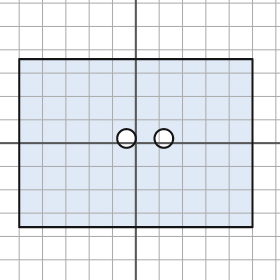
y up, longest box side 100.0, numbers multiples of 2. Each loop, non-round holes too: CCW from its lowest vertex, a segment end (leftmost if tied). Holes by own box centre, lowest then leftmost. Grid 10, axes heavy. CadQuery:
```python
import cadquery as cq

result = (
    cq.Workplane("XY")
    .moveTo(-50.0, -36.0)
    .lineTo(50.0, -36.0)
    .lineTo(50.0, 36.0)
    .lineTo(-50.0, 36.0)
    .close()
    .moveTo(-4.0, 2.0)
    .circle(4.0)
    .moveTo(12.0, 2.0)
    .circle(4.0)
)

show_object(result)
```